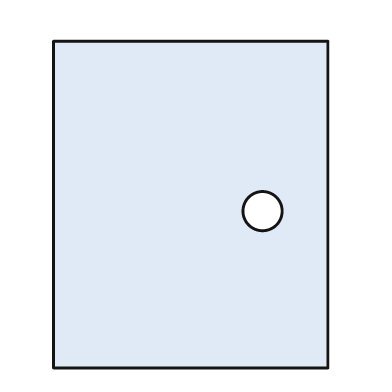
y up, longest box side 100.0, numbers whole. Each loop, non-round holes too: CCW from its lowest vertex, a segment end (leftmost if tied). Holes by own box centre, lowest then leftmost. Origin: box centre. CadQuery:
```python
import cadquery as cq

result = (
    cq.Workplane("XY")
    .moveTo(-42.0, -50.0)
    .lineTo(42.0, -50.0)
    .lineTo(42.0, 50.0)
    .lineTo(-42.0, 50.0)
    .close()
    .moveTo(22.0, -2.0)
    .circle(6.0)
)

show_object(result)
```